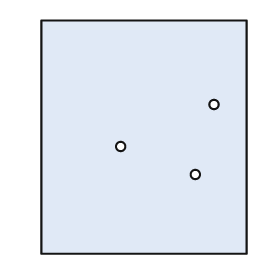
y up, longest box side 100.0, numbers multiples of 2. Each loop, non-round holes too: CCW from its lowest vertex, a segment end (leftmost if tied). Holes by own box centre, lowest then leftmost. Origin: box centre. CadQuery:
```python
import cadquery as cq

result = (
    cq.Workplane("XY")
    .moveTo(-44.0, -50.0)
    .lineTo(44.0, -50.0)
    .lineTo(44.0, 50.0)
    .lineTo(-44.0, 50.0)
    .close()
    .moveTo(22.0, -16.0)
    .circle(2.0)
    .moveTo(-10.0, -4.0)
    .circle(2.0)
    .moveTo(30.0, 14.0)
    .circle(2.0)
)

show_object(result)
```